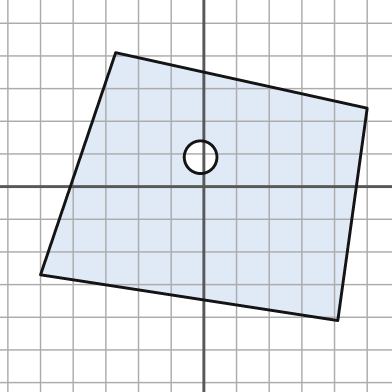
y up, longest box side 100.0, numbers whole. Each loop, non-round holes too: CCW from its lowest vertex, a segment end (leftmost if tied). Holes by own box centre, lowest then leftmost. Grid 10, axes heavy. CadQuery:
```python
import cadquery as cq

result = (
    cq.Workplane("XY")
    .moveTo(41.0, -41.0)
    .lineTo(50.0, 24.0)
    .lineTo(-27.0, 41.0)
    .lineTo(-50.0, -27.0)
    .close()
    .moveTo(-1.0, 9.0)
    .circle(5.0)
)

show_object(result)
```